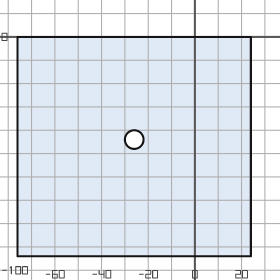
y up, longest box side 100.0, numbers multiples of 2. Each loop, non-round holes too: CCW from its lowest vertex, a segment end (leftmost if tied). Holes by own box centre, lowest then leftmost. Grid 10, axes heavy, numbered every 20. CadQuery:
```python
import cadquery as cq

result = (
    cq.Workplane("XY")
    .moveTo(-76.0, -94.0)
    .lineTo(24.0, -94.0)
    .lineTo(24.0, 0.0)
    .lineTo(-76.0, 0.0)
    .close()
    .moveTo(-26.0, -44.0)
    .circle(4.0)
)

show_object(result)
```